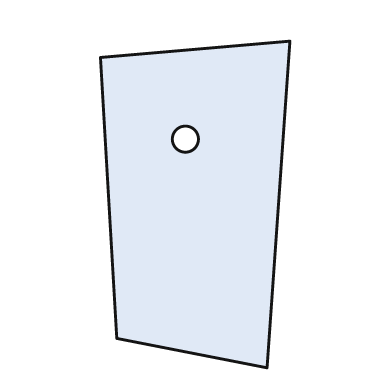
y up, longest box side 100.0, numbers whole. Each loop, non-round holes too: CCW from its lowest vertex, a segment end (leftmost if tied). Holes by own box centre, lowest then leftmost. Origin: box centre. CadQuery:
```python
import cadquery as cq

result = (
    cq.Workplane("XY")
    .moveTo(22.0, -50.0)
    .lineTo(29.0, 50.0)
    .lineTo(-29.0, 45.0)
    .lineTo(-24.0, -41.0)
    .close()
    .moveTo(-3.0, 20.0)
    .circle(4.0)
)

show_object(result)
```